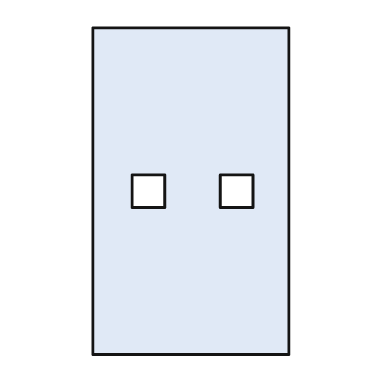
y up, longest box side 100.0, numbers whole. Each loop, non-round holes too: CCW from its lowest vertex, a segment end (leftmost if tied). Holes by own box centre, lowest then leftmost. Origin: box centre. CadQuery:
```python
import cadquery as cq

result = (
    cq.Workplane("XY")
    .moveTo(-30.0, -50.0)
    .lineTo(30.0, -50.0)
    .lineTo(30.0, 50.0)
    .lineTo(-30.0, 50.0)
    .close()
    .moveTo(-18.0, -5.0)
    .lineTo(-8.0, -5.0)
    .lineTo(-8.0, 5.0)
    .lineTo(-18.0, 5.0)
    .close()
    .moveTo(9.0, -5.0)
    .lineTo(19.0, -5.0)
    .lineTo(19.0, 5.0)
    .lineTo(9.0, 5.0)
    .close()
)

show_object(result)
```